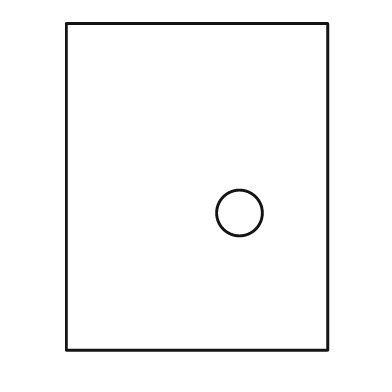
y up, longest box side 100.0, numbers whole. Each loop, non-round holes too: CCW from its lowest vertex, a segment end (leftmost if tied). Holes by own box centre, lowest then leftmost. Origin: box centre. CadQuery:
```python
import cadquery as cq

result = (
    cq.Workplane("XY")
    .moveTo(-40.0, -50.0)
    .lineTo(40.0, -50.0)
    .lineTo(40.0, 50.0)
    .lineTo(-40.0, 50.0)
    .close()
    .moveTo(13.0, -8.0)
    .circle(7.0)
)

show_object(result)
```